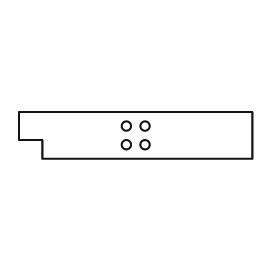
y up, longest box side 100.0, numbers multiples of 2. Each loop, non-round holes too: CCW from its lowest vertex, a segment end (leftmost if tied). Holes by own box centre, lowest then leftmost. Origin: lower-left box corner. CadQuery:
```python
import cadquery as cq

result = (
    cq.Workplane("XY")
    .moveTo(10.0, 0.0)
    .lineTo(100.0, 0.0)
    .lineTo(100.0, 20.0)
    .lineTo(0.0, 20.0)
    .lineTo(0.0, 8.0)
    .lineTo(10.0, 8.0)
    .close()
    .moveTo(46.0, 6.0)
    .circle(2.0)
    .moveTo(54.0, 6.0)
    .circle(2.0)
    .moveTo(46.0, 14.0)
    .circle(2.0)
    .moveTo(54.0, 14.0)
    .circle(2.0)
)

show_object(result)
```